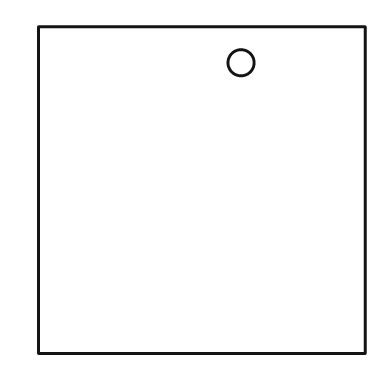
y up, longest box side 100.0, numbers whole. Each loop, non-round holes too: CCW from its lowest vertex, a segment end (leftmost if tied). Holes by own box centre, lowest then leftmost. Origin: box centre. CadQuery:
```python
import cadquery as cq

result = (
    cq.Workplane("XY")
    .moveTo(-50.0, -50.0)
    .lineTo(50.0, -50.0)
    .lineTo(50.0, 50.0)
    .lineTo(-50.0, 50.0)
    .close()
    .moveTo(12.0, 39.0)
    .circle(4.0)
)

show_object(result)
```